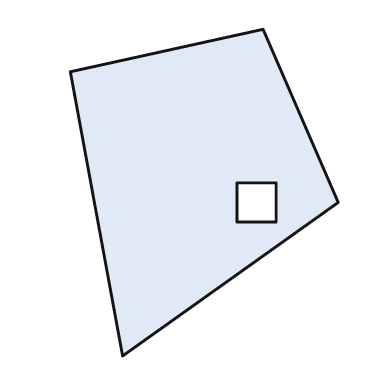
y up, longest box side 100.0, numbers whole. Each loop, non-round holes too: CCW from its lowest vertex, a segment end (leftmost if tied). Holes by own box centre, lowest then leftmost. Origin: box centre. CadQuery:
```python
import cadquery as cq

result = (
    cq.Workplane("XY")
    .moveTo(-25.0, -50.0)
    .lineTo(41.0, -3.0)
    .lineTo(18.0, 50.0)
    .lineTo(-41.0, 37.0)
    .close()
    .moveTo(10.0, -9.0)
    .lineTo(22.0, -9.0)
    .lineTo(22.0, 3.0)
    .lineTo(10.0, 3.0)
    .close()
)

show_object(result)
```